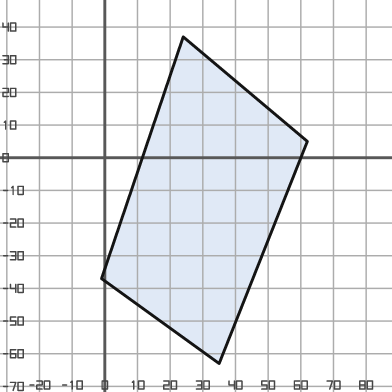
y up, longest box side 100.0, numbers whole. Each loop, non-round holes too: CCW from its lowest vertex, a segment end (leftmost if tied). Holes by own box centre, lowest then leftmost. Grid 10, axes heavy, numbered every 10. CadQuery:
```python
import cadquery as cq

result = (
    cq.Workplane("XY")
    .moveTo(35.0, -63.0)
    .lineTo(62.0, 5.0)
    .lineTo(24.0, 37.0)
    .lineTo(-1.0, -37.0)
    .close()
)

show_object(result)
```